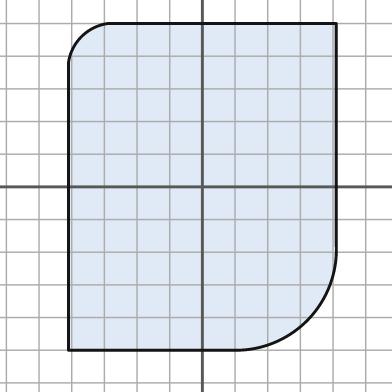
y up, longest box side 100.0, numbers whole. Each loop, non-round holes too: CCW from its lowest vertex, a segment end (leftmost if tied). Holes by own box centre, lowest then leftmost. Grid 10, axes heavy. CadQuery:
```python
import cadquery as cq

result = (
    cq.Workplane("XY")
    .moveTo(-41.0, -50.0)
    .lineTo(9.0, -50.0)
    .threePointArc((32.0, -41.0), (41.0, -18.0))
    .lineTo(41.0, 50.0)
    .lineTo(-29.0, 50.0)
    .threePointArc((-37.0, 46.0), (-41.0, 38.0))
    .close()
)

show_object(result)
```